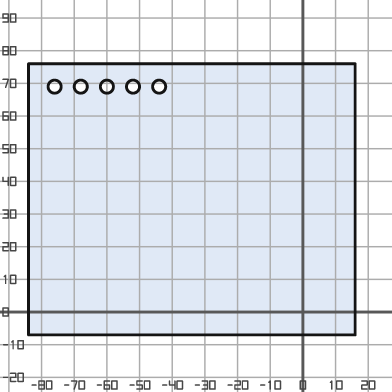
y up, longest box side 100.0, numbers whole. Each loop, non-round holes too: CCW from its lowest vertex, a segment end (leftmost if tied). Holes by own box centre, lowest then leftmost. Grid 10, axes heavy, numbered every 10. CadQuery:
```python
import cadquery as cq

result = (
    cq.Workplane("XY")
    .moveTo(-84.0, -7.0)
    .lineTo(16.0, -7.0)
    .lineTo(16.0, 76.0)
    .lineTo(-84.0, 76.0)
    .close()
    .moveTo(-76.0, 69.0)
    .circle(2.0)
    .moveTo(-68.0, 69.0)
    .circle(2.0)
    .moveTo(-60.0, 69.0)
    .circle(2.0)
    .moveTo(-52.0, 69.0)
    .circle(2.0)
    .moveTo(-44.0, 69.0)
    .circle(2.0)
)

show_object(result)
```